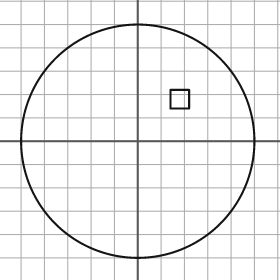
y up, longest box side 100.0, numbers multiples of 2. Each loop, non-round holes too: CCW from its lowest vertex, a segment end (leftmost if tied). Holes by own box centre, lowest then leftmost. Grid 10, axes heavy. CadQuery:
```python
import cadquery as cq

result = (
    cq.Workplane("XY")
    .moveTo(0.0, 0.0)
    .circle(50.0)
    .moveTo(14.0, 14.0)
    .lineTo(22.0, 14.0)
    .lineTo(22.0, 22.0)
    .lineTo(14.0, 22.0)
    .close()
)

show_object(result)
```